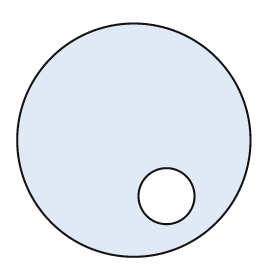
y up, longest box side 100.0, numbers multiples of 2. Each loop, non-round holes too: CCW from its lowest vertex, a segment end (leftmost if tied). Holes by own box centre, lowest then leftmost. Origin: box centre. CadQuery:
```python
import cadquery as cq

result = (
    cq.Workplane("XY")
    .moveTo(0.0, 0.0)
    .circle(50.0)
    .moveTo(14.0, -24.0)
    .circle(12.0)
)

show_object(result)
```